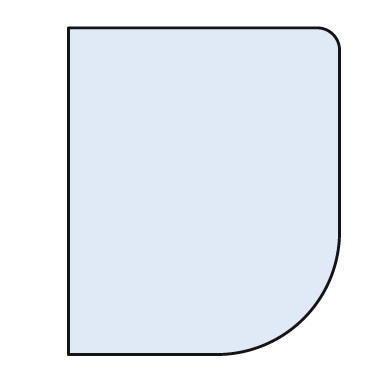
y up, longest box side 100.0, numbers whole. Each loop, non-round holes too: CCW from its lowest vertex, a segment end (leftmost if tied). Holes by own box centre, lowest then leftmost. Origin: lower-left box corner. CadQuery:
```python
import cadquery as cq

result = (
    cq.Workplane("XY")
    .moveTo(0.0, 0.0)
    .lineTo(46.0, 0.0)
    .threePointArc((72.0, 11.0), (83.0, 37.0))
    .lineTo(83.0, 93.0)
    .threePointArc((81.0, 98.0), (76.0, 100.0))
    .lineTo(0.0, 100.0)
    .close()
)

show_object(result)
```